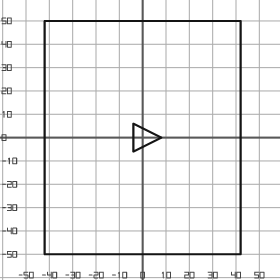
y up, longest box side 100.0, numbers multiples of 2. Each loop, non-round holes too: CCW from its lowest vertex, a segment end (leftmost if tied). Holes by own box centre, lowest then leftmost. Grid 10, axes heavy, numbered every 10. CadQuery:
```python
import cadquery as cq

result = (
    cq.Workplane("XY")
    .moveTo(-42.0, -50.0)
    .lineTo(42.0, -50.0)
    .lineTo(42.0, 50.0)
    .lineTo(-42.0, 50.0)
    .close()
    .moveTo(-4.0, -6.0)
    .lineTo(8.0, 0.0)
    .lineTo(-4.0, 6.0)
    .close()
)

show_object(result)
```